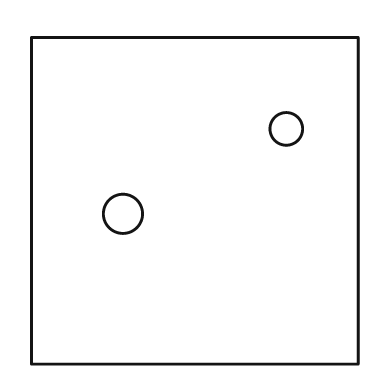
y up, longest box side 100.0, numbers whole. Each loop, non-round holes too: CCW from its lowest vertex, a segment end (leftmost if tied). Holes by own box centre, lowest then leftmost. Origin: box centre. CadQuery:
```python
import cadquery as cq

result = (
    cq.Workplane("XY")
    .moveTo(-50.0, -50.0)
    .lineTo(50.0, -50.0)
    .lineTo(50.0, 50.0)
    .lineTo(-50.0, 50.0)
    .close()
    .moveTo(-22.0, -4.0)
    .circle(6.0)
    .moveTo(28.0, 22.0)
    .circle(5.0)
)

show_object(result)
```